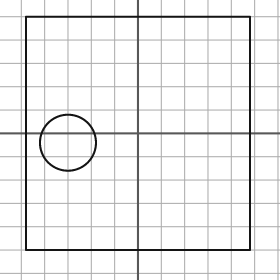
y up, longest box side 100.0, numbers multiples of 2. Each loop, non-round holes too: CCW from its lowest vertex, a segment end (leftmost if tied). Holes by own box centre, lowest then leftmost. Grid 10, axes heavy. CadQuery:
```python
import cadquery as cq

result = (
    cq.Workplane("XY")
    .moveTo(-48.0, -50.0)
    .lineTo(48.0, -50.0)
    .lineTo(48.0, 50.0)
    .lineTo(-48.0, 50.0)
    .close()
    .moveTo(-30.0, -4.0)
    .circle(12.0)
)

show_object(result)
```